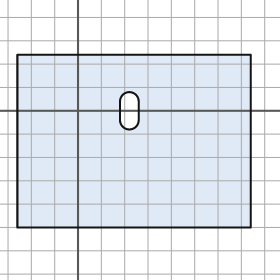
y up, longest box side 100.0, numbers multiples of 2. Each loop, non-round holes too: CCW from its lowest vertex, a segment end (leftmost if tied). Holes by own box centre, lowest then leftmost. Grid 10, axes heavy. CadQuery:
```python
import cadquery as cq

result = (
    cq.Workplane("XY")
    .moveTo(-26.0, -50.0)
    .lineTo(74.0, -50.0)
    .lineTo(74.0, 24.0)
    .lineTo(-26.0, 24.0)
    .close()
    .moveTo(18.0, -4.0)
    .threePointArc((22.0, -8.0), (26.0, -4.0))
    .lineTo(26.0, 4.0)
    .threePointArc((22.0, 8.0), (18.0, 4.0))
    .close()
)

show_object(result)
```